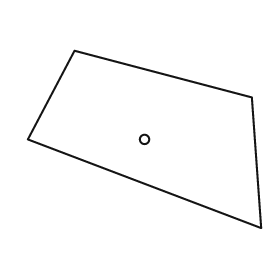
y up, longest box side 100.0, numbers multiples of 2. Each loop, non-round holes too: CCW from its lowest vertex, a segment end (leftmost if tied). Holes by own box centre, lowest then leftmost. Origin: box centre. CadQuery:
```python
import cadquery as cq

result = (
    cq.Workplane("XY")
    .moveTo(50.0, -38.0)
    .lineTo(46.0, 18.0)
    .lineTo(-30.0, 38.0)
    .lineTo(-50.0, 0.0)
    .close()
    .moveTo(0.0, 0.0)
    .circle(2.0)
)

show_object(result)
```